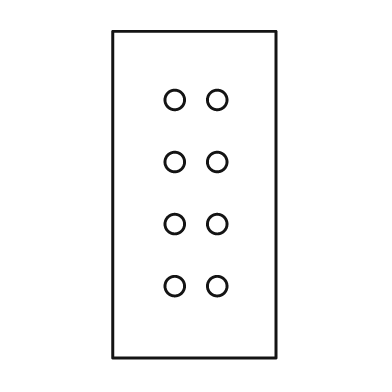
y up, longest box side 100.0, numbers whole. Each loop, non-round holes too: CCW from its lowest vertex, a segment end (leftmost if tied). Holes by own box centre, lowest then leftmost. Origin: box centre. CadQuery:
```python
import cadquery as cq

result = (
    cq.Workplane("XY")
    .moveTo(-25.0, -50.0)
    .lineTo(25.0, -50.0)
    .lineTo(25.0, 50.0)
    .lineTo(-25.0, 50.0)
    .close()
    .moveTo(-6.0, -28.0)
    .circle(3.0)
    .moveTo(7.0, -28.0)
    .circle(3.0)
    .moveTo(-6.0, -9.0)
    .circle(3.0)
    .moveTo(7.0, -9.0)
    .circle(3.0)
    .moveTo(-6.0, 10.0)
    .circle(3.0)
    .moveTo(7.0, 10.0)
    .circle(3.0)
    .moveTo(-6.0, 29.0)
    .circle(3.0)
    .moveTo(7.0, 29.0)
    .circle(3.0)
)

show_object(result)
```